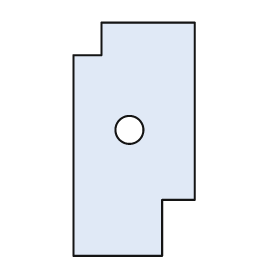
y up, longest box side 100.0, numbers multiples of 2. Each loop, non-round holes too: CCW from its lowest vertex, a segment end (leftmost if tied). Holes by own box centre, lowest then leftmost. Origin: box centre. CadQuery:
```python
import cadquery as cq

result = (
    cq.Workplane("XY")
    .moveTo(-26.0, -50.0)
    .lineTo(12.0, -50.0)
    .lineTo(12.0, -26.0)
    .lineTo(26.0, -26.0)
    .lineTo(26.0, 50.0)
    .lineTo(-14.0, 50.0)
    .lineTo(-14.0, 36.0)
    .lineTo(-26.0, 36.0)
    .close()
    .moveTo(-2.0, 4.0)
    .circle(6.0)
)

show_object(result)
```